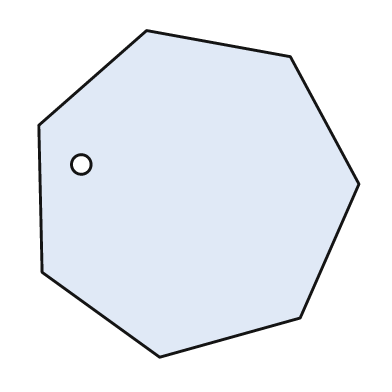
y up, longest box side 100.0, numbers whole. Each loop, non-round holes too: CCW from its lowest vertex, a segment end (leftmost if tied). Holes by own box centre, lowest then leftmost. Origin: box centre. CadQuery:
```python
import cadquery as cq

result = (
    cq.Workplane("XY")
    .moveTo(-12.0, -50.0)
    .lineTo(31.0, -38.0)
    .lineTo(49.0, 3.0)
    .lineTo(28.0, 42.0)
    .lineTo(-16.0, 50.0)
    .lineTo(-49.0, 21.0)
    .lineTo(-48.0, -24.0)
    .close()
    .moveTo(-36.0, 9.0)
    .circle(3.0)
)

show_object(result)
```